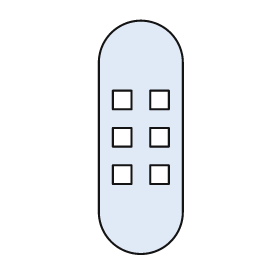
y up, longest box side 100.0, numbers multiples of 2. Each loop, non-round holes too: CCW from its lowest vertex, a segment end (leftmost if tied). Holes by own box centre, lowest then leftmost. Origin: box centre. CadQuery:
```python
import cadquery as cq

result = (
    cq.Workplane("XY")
    .moveTo(-18.0, -32.0)
    .threePointArc((0.0, -50.0), (18.0, -32.0))
    .lineTo(18.0, 32.0)
    .threePointArc((0.0, 50.0), (-18.0, 32.0))
    .close()
    .moveTo(-12.0, -20.0)
    .lineTo(-4.0, -20.0)
    .lineTo(-4.0, -12.0)
    .lineTo(-12.0, -12.0)
    .close()
    .moveTo(4.0, -20.0)
    .lineTo(12.0, -20.0)
    .lineTo(12.0, -12.0)
    .lineTo(4.0, -12.0)
    .close()
    .moveTo(-12.0, -4.0)
    .lineTo(-4.0, -4.0)
    .lineTo(-4.0, 4.0)
    .lineTo(-12.0, 4.0)
    .close()
    .moveTo(4.0, -4.0)
    .lineTo(12.0, -4.0)
    .lineTo(12.0, 4.0)
    .lineTo(4.0, 4.0)
    .close()
    .moveTo(-12.0, 12.0)
    .lineTo(-4.0, 12.0)
    .lineTo(-4.0, 20.0)
    .lineTo(-12.0, 20.0)
    .close()
    .moveTo(4.0, 12.0)
    .lineTo(12.0, 12.0)
    .lineTo(12.0, 20.0)
    .lineTo(4.0, 20.0)
    .close()
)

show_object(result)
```